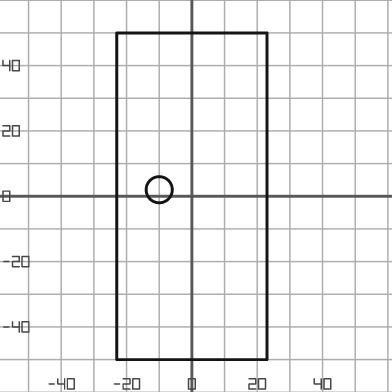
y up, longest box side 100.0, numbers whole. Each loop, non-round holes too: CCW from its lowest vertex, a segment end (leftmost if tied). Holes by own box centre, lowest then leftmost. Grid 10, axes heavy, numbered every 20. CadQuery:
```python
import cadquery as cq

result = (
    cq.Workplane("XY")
    .moveTo(-23.0, -50.0)
    .lineTo(23.0, -50.0)
    .lineTo(23.0, 50.0)
    .lineTo(-23.0, 50.0)
    .close()
    .moveTo(-10.0, 2.0)
    .circle(4.0)
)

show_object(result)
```